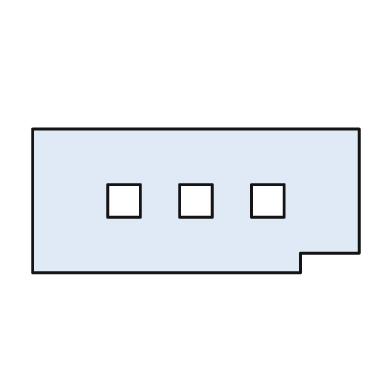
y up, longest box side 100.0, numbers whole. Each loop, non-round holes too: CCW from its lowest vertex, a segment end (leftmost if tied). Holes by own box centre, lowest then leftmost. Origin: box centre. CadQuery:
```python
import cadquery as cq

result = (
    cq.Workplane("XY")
    .moveTo(-50.0, -22.0)
    .lineTo(32.0, -22.0)
    .lineTo(32.0, -16.0)
    .lineTo(50.0, -16.0)
    .lineTo(50.0, 22.0)
    .lineTo(-50.0, 22.0)
    .close()
    .moveTo(-27.0, -5.0)
    .lineTo(-17.0, -5.0)
    .lineTo(-17.0, 5.0)
    .lineTo(-27.0, 5.0)
    .close()
    .moveTo(-5.0, -5.0)
    .lineTo(5.0, -5.0)
    .lineTo(5.0, 5.0)
    .lineTo(-5.0, 5.0)
    .close()
    .moveTo(17.0, -5.0)
    .lineTo(27.0, -5.0)
    .lineTo(27.0, 5.0)
    .lineTo(17.0, 5.0)
    .close()
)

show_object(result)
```